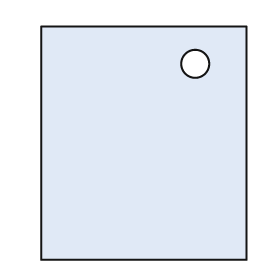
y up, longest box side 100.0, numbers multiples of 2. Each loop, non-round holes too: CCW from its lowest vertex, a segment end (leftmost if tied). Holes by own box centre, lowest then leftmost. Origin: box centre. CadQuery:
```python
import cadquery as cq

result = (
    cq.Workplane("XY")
    .moveTo(-44.0, -50.0)
    .lineTo(44.0, -50.0)
    .lineTo(44.0, 50.0)
    .lineTo(-44.0, 50.0)
    .close()
    .moveTo(22.0, 34.0)
    .circle(6.0)
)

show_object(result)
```